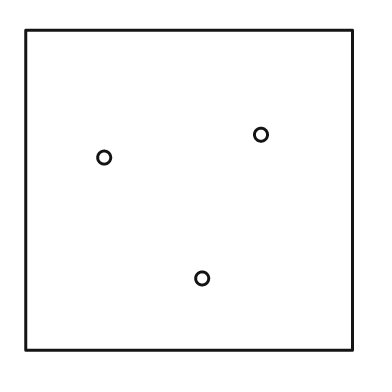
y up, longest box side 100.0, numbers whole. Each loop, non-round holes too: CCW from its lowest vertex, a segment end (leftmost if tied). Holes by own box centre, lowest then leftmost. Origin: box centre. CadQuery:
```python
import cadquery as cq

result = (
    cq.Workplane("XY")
    .moveTo(-50.0, -49.0)
    .lineTo(50.0, -49.0)
    .lineTo(50.0, 49.0)
    .lineTo(-50.0, 49.0)
    .close()
    .moveTo(4.0, -27.0)
    .circle(2.0)
    .moveTo(-26.0, 10.0)
    .circle(2.0)
    .moveTo(22.0, 17.0)
    .circle(2.0)
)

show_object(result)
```